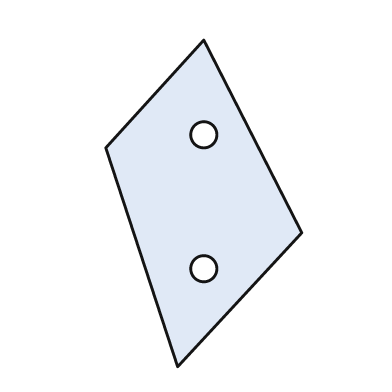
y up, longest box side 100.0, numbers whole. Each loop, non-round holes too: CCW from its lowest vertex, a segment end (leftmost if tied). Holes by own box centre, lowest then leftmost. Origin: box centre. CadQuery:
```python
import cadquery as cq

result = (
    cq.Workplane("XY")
    .moveTo(-8.0, -50.0)
    .lineTo(30.0, -9.0)
    .lineTo(0.0, 50.0)
    .lineTo(-30.0, 17.0)
    .close()
    .moveTo(0.0, -20.0)
    .circle(4.0)
    .moveTo(0.0, 21.0)
    .circle(4.0)
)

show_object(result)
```